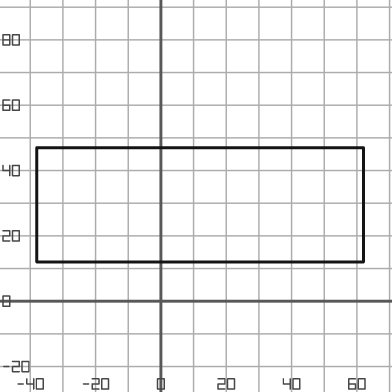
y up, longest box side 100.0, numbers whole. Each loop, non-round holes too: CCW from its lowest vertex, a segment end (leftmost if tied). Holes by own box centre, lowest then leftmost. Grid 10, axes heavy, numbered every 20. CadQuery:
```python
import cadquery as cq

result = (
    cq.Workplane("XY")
    .moveTo(-38.0, 12.0)
    .lineTo(62.0, 12.0)
    .lineTo(62.0, 47.0)
    .lineTo(-38.0, 47.0)
    .close()
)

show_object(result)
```